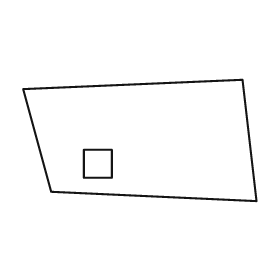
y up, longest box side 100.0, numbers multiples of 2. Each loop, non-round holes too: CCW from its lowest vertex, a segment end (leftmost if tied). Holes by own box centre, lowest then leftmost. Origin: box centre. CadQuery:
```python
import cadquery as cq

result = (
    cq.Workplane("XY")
    .moveTo(50.0, -26.0)
    .lineTo(44.0, 26.0)
    .lineTo(-50.0, 22.0)
    .lineTo(-38.0, -22.0)
    .close()
    .moveTo(-24.0, -16.0)
    .lineTo(-12.0, -16.0)
    .lineTo(-12.0, -4.0)
    .lineTo(-24.0, -4.0)
    .close()
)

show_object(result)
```